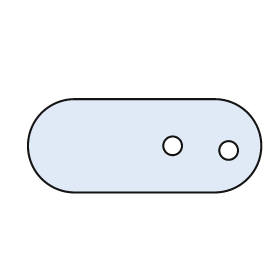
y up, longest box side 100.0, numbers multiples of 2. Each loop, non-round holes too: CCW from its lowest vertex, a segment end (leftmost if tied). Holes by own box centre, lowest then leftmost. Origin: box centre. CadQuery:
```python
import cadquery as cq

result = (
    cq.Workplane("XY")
    .moveTo(-30.0, -20.0)
    .lineTo(30.0, -20.0)
    .threePointArc((50.0, 0.0), (30.0, 20.0))
    .lineTo(-30.0, 20.0)
    .threePointArc((-50.0, 0.0), (-30.0, -20.0))
    .close()
    .moveTo(36.0, -2.0)
    .circle(4.0)
    .moveTo(12.0, 0.0)
    .circle(4.0)
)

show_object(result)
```